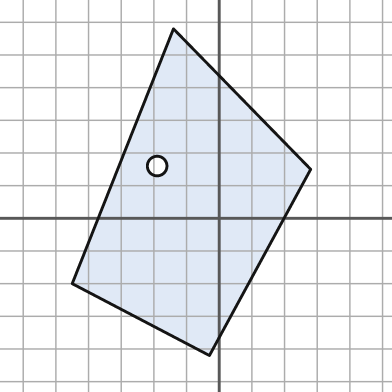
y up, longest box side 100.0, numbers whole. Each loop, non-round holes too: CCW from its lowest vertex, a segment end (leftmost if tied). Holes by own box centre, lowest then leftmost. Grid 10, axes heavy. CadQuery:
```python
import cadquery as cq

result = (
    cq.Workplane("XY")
    .moveTo(-3.0, -42.0)
    .lineTo(28.0, 15.0)
    .lineTo(-14.0, 58.0)
    .lineTo(-45.0, -20.0)
    .close()
    .moveTo(-19.0, 16.0)
    .circle(3.0)
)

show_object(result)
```